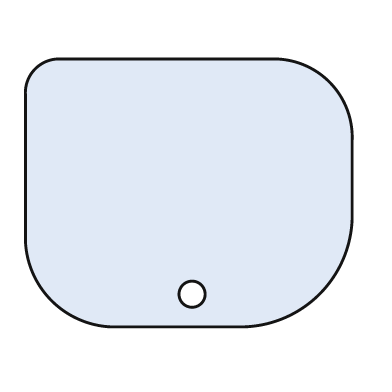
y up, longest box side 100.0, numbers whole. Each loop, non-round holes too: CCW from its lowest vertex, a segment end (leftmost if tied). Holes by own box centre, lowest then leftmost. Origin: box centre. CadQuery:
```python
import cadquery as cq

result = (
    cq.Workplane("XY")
    .moveTo(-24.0, -41.0)
    .lineTo(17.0, -41.0)
    .threePointArc((40.0, -31.0), (50.0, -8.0))
    .lineTo(50.0, 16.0)
    .threePointArc((43.0, 34.0), (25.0, 41.0))
    .lineTo(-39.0, 41.0)
    .threePointArc((-47.0, 38.0), (-50.0, 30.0))
    .lineTo(-50.0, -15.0)
    .threePointArc((-42.0, -33.0), (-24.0, -41.0))
    .close()
    .moveTo(1.0, -31.0)
    .circle(4.0)
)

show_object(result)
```